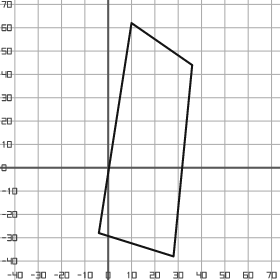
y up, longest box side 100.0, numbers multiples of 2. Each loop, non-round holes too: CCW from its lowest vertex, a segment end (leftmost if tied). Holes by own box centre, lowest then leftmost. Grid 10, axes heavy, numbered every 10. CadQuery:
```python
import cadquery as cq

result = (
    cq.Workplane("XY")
    .moveTo(28.0, -38.0)
    .lineTo(36.0, 44.0)
    .lineTo(10.0, 62.0)
    .lineTo(-4.0, -28.0)
    .close()
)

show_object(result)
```